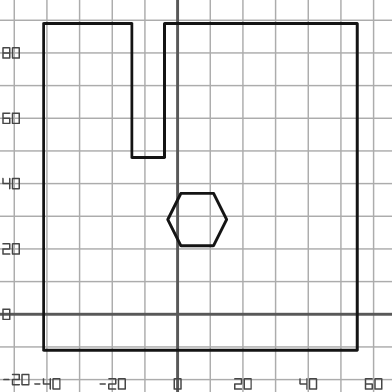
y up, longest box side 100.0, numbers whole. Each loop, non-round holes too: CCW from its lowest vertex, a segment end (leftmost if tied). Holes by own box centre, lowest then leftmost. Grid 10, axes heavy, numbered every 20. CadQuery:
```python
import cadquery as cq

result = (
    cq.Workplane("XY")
    .moveTo(-41.0, -11.0)
    .lineTo(55.0, -11.0)
    .lineTo(55.0, 89.0)
    .lineTo(-4.0, 89.0)
    .lineTo(-4.0, 48.0)
    .lineTo(-14.0, 48.0)
    .lineTo(-14.0, 89.0)
    .lineTo(-41.0, 89.0)
    .close()
    .moveTo(1.0, 21.0)
    .lineTo(11.0, 21.0)
    .lineTo(15.0, 29.0)
    .lineTo(11.0, 37.0)
    .lineTo(1.0, 37.0)
    .lineTo(-3.0, 29.0)
    .close()
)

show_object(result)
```